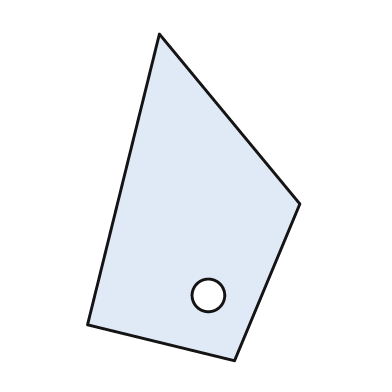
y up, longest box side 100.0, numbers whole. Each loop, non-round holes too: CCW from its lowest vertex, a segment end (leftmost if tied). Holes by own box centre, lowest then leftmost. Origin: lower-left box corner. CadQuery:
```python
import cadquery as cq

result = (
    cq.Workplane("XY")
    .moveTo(45.0, 0.0)
    .lineTo(65.0, 48.0)
    .lineTo(22.0, 100.0)
    .lineTo(0.0, 11.0)
    .close()
    .moveTo(37.0, 20.0)
    .circle(5.0)
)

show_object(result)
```